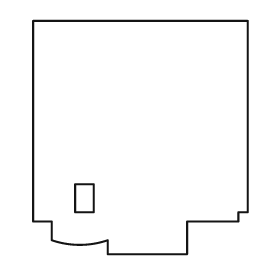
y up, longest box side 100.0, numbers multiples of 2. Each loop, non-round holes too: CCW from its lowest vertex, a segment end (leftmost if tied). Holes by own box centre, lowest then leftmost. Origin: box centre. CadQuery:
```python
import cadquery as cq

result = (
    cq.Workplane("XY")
    .moveTo(-14.0, -50.0)
    .lineTo(20.0, -50.0)
    .lineTo(20.0, -36.0)
    .lineTo(42.0, -36.0)
    .lineTo(42.0, -32.0)
    .lineTo(46.0, -32.0)
    .lineTo(46.0, 50.0)
    .lineTo(-46.0, 50.0)
    .lineTo(-46.0, -36.0)
    .lineTo(-38.0, -36.0)
    .lineTo(-38.0, -44.0)
    .threePointArc((-26.0, -46.0), (-14.0, -44.0))
    .close()
    .moveTo(-28.0, -32.0)
    .lineTo(-20.0, -32.0)
    .lineTo(-20.0, -20.0)
    .lineTo(-28.0, -20.0)
    .close()
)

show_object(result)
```